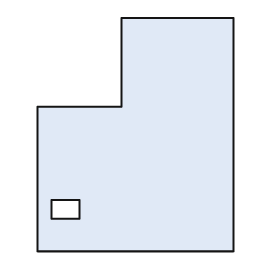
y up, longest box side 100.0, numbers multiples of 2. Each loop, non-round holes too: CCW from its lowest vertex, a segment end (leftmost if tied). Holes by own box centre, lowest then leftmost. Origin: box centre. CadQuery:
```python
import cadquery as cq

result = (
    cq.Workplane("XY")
    .moveTo(-42.0, -50.0)
    .lineTo(42.0, -50.0)
    .lineTo(42.0, 50.0)
    .lineTo(-6.0, 50.0)
    .lineTo(-6.0, 12.0)
    .lineTo(-42.0, 12.0)
    .close()
    .moveTo(-36.0, -36.0)
    .lineTo(-24.0, -36.0)
    .lineTo(-24.0, -28.0)
    .lineTo(-36.0, -28.0)
    .close()
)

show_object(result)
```